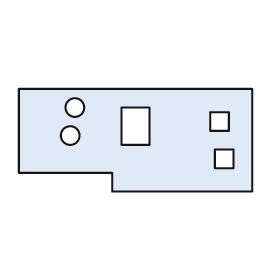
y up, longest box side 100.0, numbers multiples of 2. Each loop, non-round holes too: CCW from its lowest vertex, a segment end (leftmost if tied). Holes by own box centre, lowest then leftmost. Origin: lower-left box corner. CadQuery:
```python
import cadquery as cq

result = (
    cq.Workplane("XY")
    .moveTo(40.0, 0.0)
    .lineTo(100.0, 0.0)
    .lineTo(100.0, 44.0)
    .lineTo(0.0, 44.0)
    .lineTo(0.0, 8.0)
    .lineTo(40.0, 8.0)
    .close()
    .moveTo(84.0, 10.0)
    .lineTo(92.0, 10.0)
    .lineTo(92.0, 18.0)
    .lineTo(84.0, 18.0)
    .close()
    .moveTo(22.0, 24.0)
    .circle(4.0)
    .moveTo(44.0, 20.0)
    .lineTo(56.0, 20.0)
    .lineTo(56.0, 36.0)
    .lineTo(44.0, 36.0)
    .close()
    .moveTo(82.0, 26.0)
    .lineTo(90.0, 26.0)
    .lineTo(90.0, 34.0)
    .lineTo(82.0, 34.0)
    .close()
    .moveTo(24.0, 36.0)
    .circle(4.0)
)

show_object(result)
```